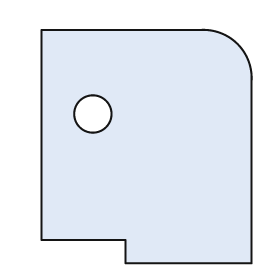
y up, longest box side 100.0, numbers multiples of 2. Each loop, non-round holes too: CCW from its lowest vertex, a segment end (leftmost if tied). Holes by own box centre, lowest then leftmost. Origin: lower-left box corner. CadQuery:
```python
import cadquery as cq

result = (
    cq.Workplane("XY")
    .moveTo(36.0, 0.0)
    .lineTo(90.0, 0.0)
    .lineTo(90.0, 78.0)
    .threePointArc((84.0, 94.0), (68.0, 100.0))
    .lineTo(0.0, 100.0)
    .lineTo(0.0, 10.0)
    .lineTo(36.0, 10.0)
    .close()
    .moveTo(22.0, 64.0)
    .circle(8.0)
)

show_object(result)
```